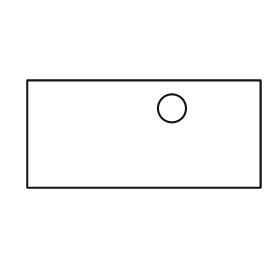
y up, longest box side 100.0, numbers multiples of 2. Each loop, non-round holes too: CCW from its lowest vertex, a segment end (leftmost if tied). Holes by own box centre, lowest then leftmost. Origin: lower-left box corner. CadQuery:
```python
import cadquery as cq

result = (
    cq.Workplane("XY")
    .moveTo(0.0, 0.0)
    .lineTo(100.0, 0.0)
    .lineTo(100.0, 46.0)
    .lineTo(0.0, 46.0)
    .close()
    .moveTo(62.0, 34.0)
    .circle(6.0)
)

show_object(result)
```